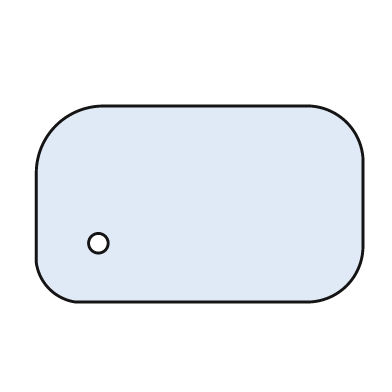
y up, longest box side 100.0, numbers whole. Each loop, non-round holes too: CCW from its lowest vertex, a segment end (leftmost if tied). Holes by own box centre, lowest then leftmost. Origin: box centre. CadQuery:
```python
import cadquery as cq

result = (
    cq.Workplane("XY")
    .moveTo(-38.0, -30.0)
    .lineTo(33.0, -30.0)
    .threePointArc((45.0, -25.0), (50.0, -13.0))
    .lineTo(50.0, 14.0)
    .threePointArc((45.0, 25.0), (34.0, 30.0))
    .lineTo(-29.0, 30.0)
    .threePointArc((-44.0, 24.0), (-50.0, 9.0))
    .lineTo(-50.0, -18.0)
    .threePointArc((-46.0, -26.0), (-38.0, -30.0))
    .close()
    .moveTo(-31.0, -12.0)
    .circle(3.0)
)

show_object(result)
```